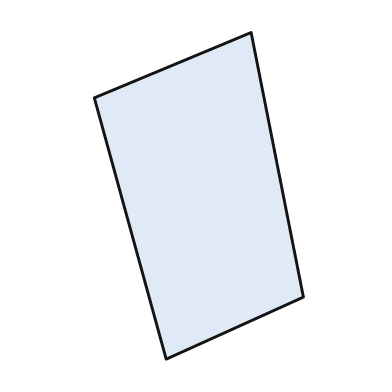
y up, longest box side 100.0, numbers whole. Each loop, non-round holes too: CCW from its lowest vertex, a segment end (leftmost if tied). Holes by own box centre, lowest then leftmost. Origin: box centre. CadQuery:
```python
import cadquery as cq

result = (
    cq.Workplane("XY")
    .moveTo(-10.0, -50.0)
    .lineTo(32.0, -31.0)
    .lineTo(16.0, 50.0)
    .lineTo(-32.0, 30.0)
    .close()
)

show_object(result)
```